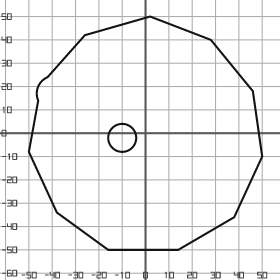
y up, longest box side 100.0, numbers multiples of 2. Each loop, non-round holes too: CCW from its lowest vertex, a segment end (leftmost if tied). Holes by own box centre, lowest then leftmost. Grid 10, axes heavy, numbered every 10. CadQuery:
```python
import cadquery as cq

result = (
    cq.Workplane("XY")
    .moveTo(-16.0, -50.0)
    .lineTo(14.0, -50.0)
    .lineTo(38.0, -36.0)
    .lineTo(50.0, -10.0)
    .lineTo(46.0, 18.0)
    .lineTo(28.0, 40.0)
    .lineTo(2.0, 50.0)
    .lineTo(-26.0, 42.0)
    .lineTo(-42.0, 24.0)
    .threePointArc((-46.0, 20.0), (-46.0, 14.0))
    .lineTo(-50.0, -8.0)
    .lineTo(-38.0, -34.0)
    .close()
    .moveTo(-10.0, -2.0)
    .circle(6.0)
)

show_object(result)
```